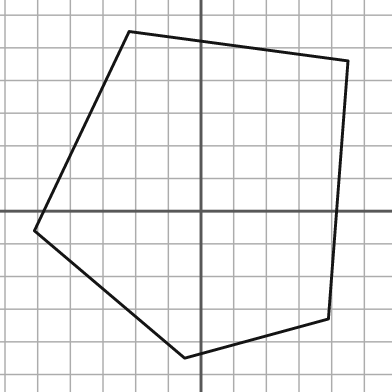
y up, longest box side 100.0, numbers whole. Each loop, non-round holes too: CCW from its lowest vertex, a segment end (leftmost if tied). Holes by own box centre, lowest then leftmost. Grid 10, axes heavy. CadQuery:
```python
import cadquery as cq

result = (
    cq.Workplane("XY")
    .moveTo(-5.0, -45.0)
    .lineTo(39.0, -33.0)
    .lineTo(45.0, 46.0)
    .lineTo(-22.0, 55.0)
    .lineTo(-51.0, -6.0)
    .close()
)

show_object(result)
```